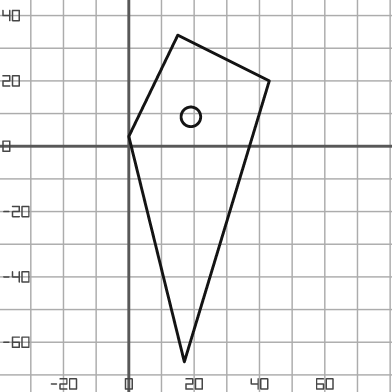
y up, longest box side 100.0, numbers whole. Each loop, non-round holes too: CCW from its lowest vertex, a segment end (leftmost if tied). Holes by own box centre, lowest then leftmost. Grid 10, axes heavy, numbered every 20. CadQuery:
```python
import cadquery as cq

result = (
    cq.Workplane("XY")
    .moveTo(17.0, -66.0)
    .lineTo(43.0, 20.0)
    .lineTo(15.0, 34.0)
    .lineTo(0.0, 3.0)
    .close()
    .moveTo(19.0, 9.0)
    .circle(3.0)
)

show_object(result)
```